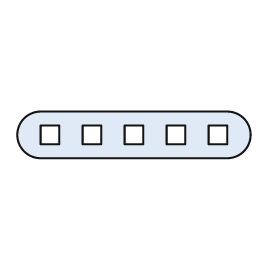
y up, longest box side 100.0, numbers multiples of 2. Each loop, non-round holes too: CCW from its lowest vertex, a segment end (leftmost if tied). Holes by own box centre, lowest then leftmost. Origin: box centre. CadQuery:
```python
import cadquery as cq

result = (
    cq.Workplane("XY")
    .moveTo(-40.0, -10.0)
    .lineTo(40.0, -10.0)
    .threePointArc((50.0, 0.0), (40.0, 10.0))
    .lineTo(-40.0, 10.0)
    .threePointArc((-50.0, 0.0), (-40.0, -10.0))
    .close()
    .moveTo(-40.0, -4.0)
    .lineTo(-32.0, -4.0)
    .lineTo(-32.0, 4.0)
    .lineTo(-40.0, 4.0)
    .close()
    .moveTo(-22.0, -4.0)
    .lineTo(-14.0, -4.0)
    .lineTo(-14.0, 4.0)
    .lineTo(-22.0, 4.0)
    .close()
    .moveTo(-4.0, -4.0)
    .lineTo(4.0, -4.0)
    .lineTo(4.0, 4.0)
    .lineTo(-4.0, 4.0)
    .close()
    .moveTo(14.0, -4.0)
    .lineTo(22.0, -4.0)
    .lineTo(22.0, 4.0)
    .lineTo(14.0, 4.0)
    .close()
    .moveTo(32.0, -4.0)
    .lineTo(40.0, -4.0)
    .lineTo(40.0, 4.0)
    .lineTo(32.0, 4.0)
    .close()
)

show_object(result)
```